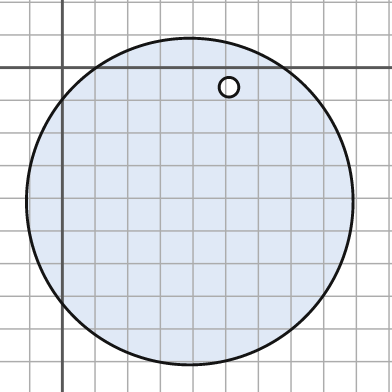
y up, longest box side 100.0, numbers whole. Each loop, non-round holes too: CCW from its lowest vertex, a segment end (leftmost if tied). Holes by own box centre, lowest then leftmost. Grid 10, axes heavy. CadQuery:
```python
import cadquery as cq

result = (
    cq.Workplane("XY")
    .moveTo(39.0, -41.0)
    .circle(50.0)
    .moveTo(51.0, -6.0)
    .circle(3.0)
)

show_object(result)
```